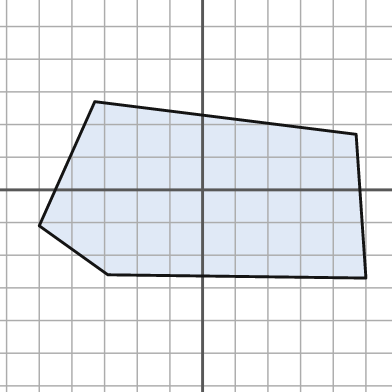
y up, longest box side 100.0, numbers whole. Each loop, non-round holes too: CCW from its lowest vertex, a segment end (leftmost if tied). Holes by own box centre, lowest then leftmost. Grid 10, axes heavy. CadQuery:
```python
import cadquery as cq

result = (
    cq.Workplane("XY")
    .moveTo(50.0, -27.0)
    .lineTo(47.0, 17.0)
    .lineTo(-33.0, 27.0)
    .lineTo(-50.0, -11.0)
    .lineTo(-29.0, -26.0)
    .close()
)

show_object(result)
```